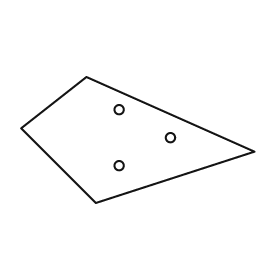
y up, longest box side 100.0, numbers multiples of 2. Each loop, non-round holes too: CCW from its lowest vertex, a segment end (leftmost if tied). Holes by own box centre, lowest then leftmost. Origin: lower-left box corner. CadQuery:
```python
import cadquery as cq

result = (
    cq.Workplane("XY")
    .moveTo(32.0, 0.0)
    .lineTo(100.0, 22.0)
    .lineTo(28.0, 54.0)
    .lineTo(0.0, 32.0)
    .close()
    .moveTo(42.0, 16.0)
    .circle(2.0)
    .moveTo(64.0, 28.0)
    .circle(2.0)
    .moveTo(42.0, 40.0)
    .circle(2.0)
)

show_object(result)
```